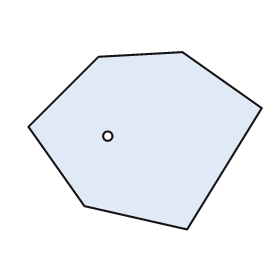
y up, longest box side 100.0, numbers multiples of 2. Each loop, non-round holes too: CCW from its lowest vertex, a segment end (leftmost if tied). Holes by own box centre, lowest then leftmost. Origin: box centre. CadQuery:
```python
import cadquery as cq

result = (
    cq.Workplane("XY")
    .moveTo(18.0, -38.0)
    .lineTo(50.0, 14.0)
    .lineTo(16.0, 38.0)
    .lineTo(-20.0, 36.0)
    .lineTo(-50.0, 6.0)
    .lineTo(-26.0, -28.0)
    .close()
    .moveTo(-16.0, 2.0)
    .circle(2.0)
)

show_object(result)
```